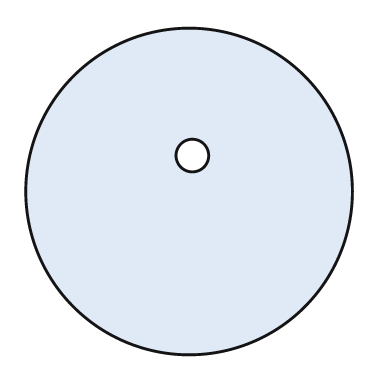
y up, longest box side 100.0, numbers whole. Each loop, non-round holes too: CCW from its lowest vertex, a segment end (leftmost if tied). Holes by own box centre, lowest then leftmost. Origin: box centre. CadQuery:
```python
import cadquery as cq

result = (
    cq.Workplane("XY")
    .moveTo(0.0, 0.0)
    .circle(50.0)
    .moveTo(1.0, 11.0)
    .circle(5.0)
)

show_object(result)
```